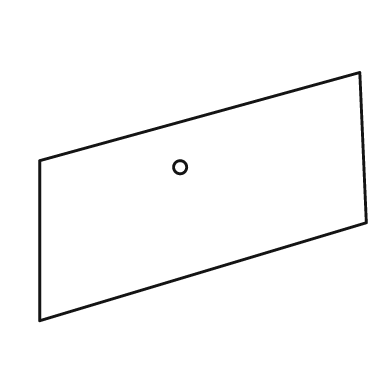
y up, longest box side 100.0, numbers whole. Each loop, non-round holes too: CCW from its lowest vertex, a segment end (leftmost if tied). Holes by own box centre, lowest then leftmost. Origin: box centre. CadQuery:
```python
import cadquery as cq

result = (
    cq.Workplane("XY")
    .moveTo(-50.0, -38.0)
    .lineTo(50.0, -8.0)
    .lineTo(48.0, 38.0)
    .lineTo(-50.0, 11.0)
    .close()
    .moveTo(-7.0, 9.0)
    .circle(2.0)
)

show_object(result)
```